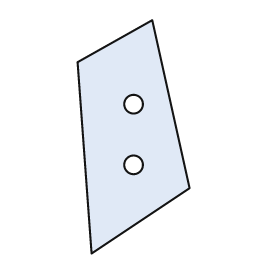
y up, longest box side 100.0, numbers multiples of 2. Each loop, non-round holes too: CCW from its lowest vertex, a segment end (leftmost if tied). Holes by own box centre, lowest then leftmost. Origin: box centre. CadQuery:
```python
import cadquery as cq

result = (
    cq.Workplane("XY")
    .moveTo(-18.0, -50.0)
    .lineTo(24.0, -22.0)
    .lineTo(8.0, 50.0)
    .lineTo(-24.0, 32.0)
    .close()
    .moveTo(0.0, -12.0)
    .circle(4.0)
    .moveTo(0.0, 14.0)
    .circle(4.0)
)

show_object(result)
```